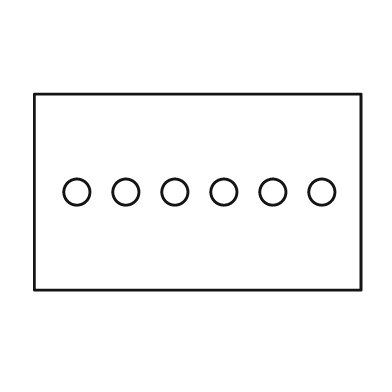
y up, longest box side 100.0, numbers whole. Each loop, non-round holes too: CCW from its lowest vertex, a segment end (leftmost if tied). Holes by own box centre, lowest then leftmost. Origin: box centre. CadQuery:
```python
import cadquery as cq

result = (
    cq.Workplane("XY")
    .moveTo(-50.0, -30.0)
    .lineTo(50.0, -30.0)
    .lineTo(50.0, 30.0)
    .lineTo(-50.0, 30.0)
    .close()
    .moveTo(-37.0, 0.0)
    .circle(4.0)
    .moveTo(-22.0, 0.0)
    .circle(4.0)
    .moveTo(-7.0, 0.0)
    .circle(4.0)
    .moveTo(8.0, 0.0)
    .circle(4.0)
    .moveTo(23.0, 0.0)
    .circle(4.0)
    .moveTo(38.0, 0.0)
    .circle(4.0)
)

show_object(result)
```